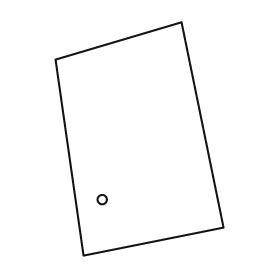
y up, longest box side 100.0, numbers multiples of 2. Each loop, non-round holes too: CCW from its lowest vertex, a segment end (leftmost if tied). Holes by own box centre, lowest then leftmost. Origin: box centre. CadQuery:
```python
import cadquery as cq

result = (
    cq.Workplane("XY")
    .moveTo(-24.0, -50.0)
    .lineTo(36.0, -38.0)
    .lineTo(18.0, 50.0)
    .lineTo(-36.0, 34.0)
    .close()
    .moveTo(-16.0, -26.0)
    .circle(2.0)
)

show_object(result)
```